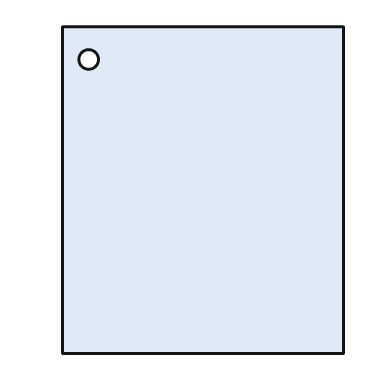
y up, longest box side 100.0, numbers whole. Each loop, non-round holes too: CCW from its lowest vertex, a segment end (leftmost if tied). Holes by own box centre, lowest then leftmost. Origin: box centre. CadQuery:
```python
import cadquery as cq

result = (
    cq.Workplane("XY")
    .moveTo(-43.0, -50.0)
    .lineTo(43.0, -50.0)
    .lineTo(43.0, 50.0)
    .lineTo(-43.0, 50.0)
    .close()
    .moveTo(-35.0, 40.0)
    .circle(3.0)
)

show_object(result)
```